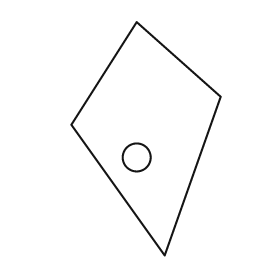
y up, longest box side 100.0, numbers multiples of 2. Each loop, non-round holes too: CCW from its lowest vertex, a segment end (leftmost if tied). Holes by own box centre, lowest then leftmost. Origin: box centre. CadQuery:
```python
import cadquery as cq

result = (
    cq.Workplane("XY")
    .moveTo(8.0, -50.0)
    .lineTo(32.0, 18.0)
    .lineTo(-4.0, 50.0)
    .lineTo(-32.0, 6.0)
    .close()
    .moveTo(-4.0, -8.0)
    .circle(6.0)
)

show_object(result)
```